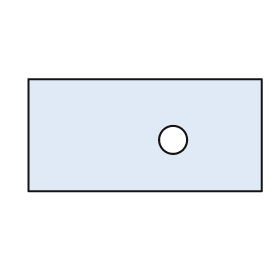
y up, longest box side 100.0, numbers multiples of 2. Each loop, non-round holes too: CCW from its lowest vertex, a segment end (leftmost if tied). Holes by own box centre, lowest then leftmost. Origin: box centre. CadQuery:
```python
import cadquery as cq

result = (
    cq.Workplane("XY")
    .moveTo(-50.0, -24.0)
    .lineTo(50.0, -24.0)
    .lineTo(50.0, 24.0)
    .lineTo(-50.0, 24.0)
    .close()
    .moveTo(12.0, -2.0)
    .circle(6.0)
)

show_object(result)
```